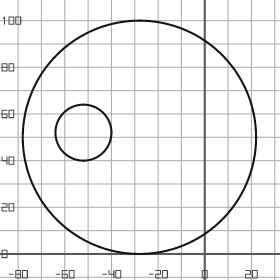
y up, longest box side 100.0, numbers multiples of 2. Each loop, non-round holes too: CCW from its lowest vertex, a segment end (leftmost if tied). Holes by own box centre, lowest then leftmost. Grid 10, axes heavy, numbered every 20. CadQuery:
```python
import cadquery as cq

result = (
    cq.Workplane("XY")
    .moveTo(-28.0, 50.0)
    .circle(50.0)
    .moveTo(-52.0, 52.0)
    .circle(12.0)
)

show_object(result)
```